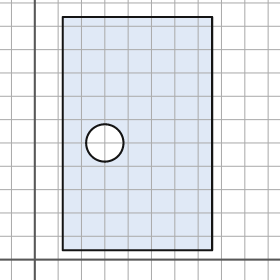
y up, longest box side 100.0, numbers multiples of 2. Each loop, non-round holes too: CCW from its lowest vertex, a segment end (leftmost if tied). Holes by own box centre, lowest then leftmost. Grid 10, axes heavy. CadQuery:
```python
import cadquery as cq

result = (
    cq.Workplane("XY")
    .moveTo(12.0, 4.0)
    .lineTo(76.0, 4.0)
    .lineTo(76.0, 104.0)
    .lineTo(12.0, 104.0)
    .close()
    .moveTo(30.0, 50.0)
    .circle(8.0)
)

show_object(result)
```